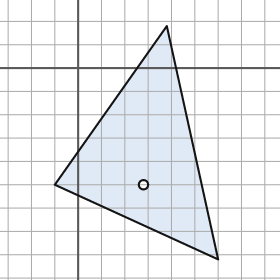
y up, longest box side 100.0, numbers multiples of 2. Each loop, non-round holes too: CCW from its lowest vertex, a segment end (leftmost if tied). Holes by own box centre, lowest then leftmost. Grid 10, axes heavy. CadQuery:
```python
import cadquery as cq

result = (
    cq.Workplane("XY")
    .moveTo(60.0, -82.0)
    .lineTo(38.0, 18.0)
    .lineTo(-10.0, -50.0)
    .close()
    .moveTo(28.0, -50.0)
    .circle(2.0)
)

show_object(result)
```